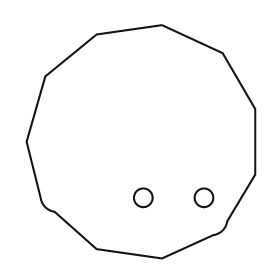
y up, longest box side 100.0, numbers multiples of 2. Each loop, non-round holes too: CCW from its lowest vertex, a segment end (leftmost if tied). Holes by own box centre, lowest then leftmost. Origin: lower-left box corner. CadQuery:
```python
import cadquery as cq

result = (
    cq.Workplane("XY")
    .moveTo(58.0, 0.0)
    .lineTo(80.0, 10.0)
    .threePointArc((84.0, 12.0), (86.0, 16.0))
    .lineTo(98.0, 36.0)
    .lineTo(98.0, 64.0)
    .lineTo(84.0, 88.0)
    .lineTo(58.0, 100.0)
    .lineTo(30.0, 96.0)
    .lineTo(8.0, 78.0)
    .lineTo(0.0, 50.0)
    .lineTo(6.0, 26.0)
    .threePointArc((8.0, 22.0), (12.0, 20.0))
    .lineTo(30.0, 4.0)
    .close()
    .moveTo(50.0, 26.0)
    .circle(4.0)
    .moveTo(76.0, 26.0)
    .circle(4.0)
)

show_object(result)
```